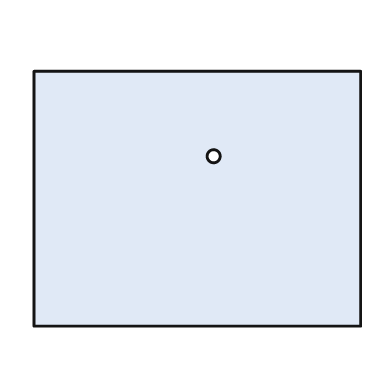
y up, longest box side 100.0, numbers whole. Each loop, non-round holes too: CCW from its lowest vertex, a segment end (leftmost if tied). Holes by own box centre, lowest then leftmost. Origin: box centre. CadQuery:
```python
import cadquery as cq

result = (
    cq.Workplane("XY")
    .moveTo(-50.0, -39.0)
    .lineTo(50.0, -39.0)
    .lineTo(50.0, 39.0)
    .lineTo(-50.0, 39.0)
    .close()
    .moveTo(5.0, 13.0)
    .circle(2.0)
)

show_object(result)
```